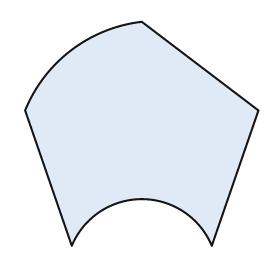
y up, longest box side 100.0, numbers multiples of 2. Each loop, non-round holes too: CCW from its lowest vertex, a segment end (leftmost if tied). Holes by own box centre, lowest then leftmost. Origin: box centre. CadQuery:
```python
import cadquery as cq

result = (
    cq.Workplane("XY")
    .moveTo(-30.0, -48.0)
    .threePointArc((0.0, -28.0), (30.0, -48.0))
    .lineTo(50.0, 10.0)
    .lineTo(0.0, 48.0)
    .threePointArc((-30.0, 36.0), (-50.0, 10.0))
    .close()
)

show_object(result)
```